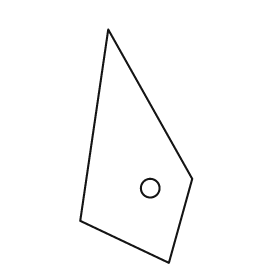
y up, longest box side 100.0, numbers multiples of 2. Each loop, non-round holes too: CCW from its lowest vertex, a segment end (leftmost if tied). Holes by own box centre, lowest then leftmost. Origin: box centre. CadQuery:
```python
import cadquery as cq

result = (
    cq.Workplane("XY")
    .moveTo(14.0, -50.0)
    .lineTo(24.0, -14.0)
    .lineTo(-12.0, 50.0)
    .lineTo(-24.0, -32.0)
    .close()
    .moveTo(6.0, -18.0)
    .circle(4.0)
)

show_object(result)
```